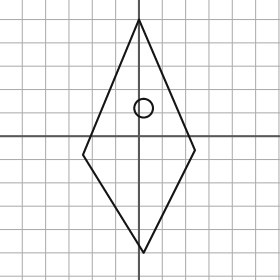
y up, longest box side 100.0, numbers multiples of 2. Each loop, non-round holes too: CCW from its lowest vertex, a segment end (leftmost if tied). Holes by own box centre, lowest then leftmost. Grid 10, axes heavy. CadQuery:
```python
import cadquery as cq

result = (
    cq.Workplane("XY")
    .moveTo(2.0, -50.0)
    .lineTo(24.0, -6.0)
    .lineTo(0.0, 50.0)
    .lineTo(-24.0, -8.0)
    .close()
    .moveTo(2.0, 12.0)
    .circle(4.0)
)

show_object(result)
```